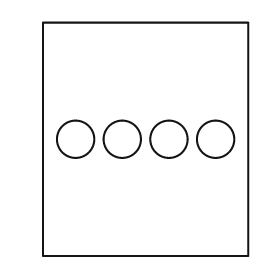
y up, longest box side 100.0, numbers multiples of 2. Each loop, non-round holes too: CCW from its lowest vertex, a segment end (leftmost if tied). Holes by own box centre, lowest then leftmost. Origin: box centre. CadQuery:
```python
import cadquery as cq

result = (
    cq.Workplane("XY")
    .moveTo(-44.0, -50.0)
    .lineTo(44.0, -50.0)
    .lineTo(44.0, 50.0)
    .lineTo(-44.0, 50.0)
    .close()
    .moveTo(-30.0, 0.0)
    .circle(8.0)
    .moveTo(-10.0, 0.0)
    .circle(8.0)
    .moveTo(10.0, 0.0)
    .circle(8.0)
    .moveTo(30.0, 0.0)
    .circle(8.0)
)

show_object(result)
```